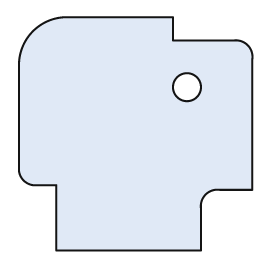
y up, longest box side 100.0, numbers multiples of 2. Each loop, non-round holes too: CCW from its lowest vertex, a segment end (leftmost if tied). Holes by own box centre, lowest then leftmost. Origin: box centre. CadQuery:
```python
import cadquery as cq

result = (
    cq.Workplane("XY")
    .moveTo(-34.0, -50.0)
    .lineTo(28.0, -50.0)
    .lineTo(28.0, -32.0)
    .threePointArc((30.0, -26.0), (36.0, -24.0))
    .lineTo(50.0, -24.0)
    .lineTo(50.0, 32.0)
    .threePointArc((48.0, 38.0), (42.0, 40.0))
    .lineTo(16.0, 40.0)
    .lineTo(16.0, 50.0)
    .lineTo(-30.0, 50.0)
    .threePointArc((-44.0, 44.0), (-50.0, 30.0))
    .lineTo(-50.0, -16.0)
    .threePointArc((-48.0, -20.0), (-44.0, -22.0))
    .lineTo(-34.0, -22.0)
    .close()
    .moveTo(22.0, 20.0)
    .circle(6.0)
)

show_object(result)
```